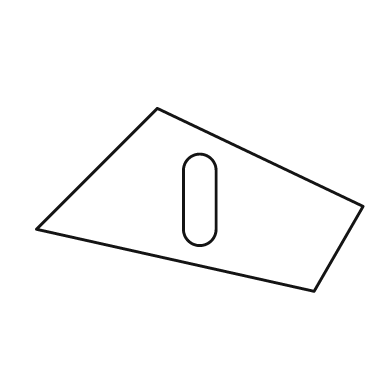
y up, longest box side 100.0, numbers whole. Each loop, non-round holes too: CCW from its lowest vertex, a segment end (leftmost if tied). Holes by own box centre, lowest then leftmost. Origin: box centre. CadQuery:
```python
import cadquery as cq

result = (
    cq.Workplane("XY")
    .moveTo(35.0, -28.0)
    .lineTo(50.0, -2.0)
    .lineTo(-13.0, 28.0)
    .lineTo(-50.0, -9.0)
    .close()
    .moveTo(-5.0, -9.0)
    .threePointArc((0.0, -14.0), (5.0, -9.0))
    .lineTo(5.0, 9.0)
    .threePointArc((0.0, 14.0), (-5.0, 9.0))
    .close()
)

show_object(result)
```